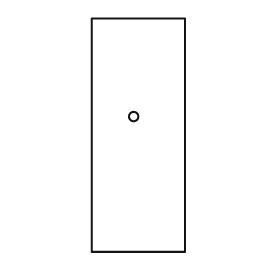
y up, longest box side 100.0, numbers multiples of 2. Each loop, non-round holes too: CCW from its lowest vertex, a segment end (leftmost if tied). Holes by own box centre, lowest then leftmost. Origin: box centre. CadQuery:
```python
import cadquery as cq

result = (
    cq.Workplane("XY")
    .moveTo(-20.0, -50.0)
    .lineTo(20.0, -50.0)
    .lineTo(20.0, 50.0)
    .lineTo(-20.0, 50.0)
    .close()
    .moveTo(-2.0, 8.0)
    .circle(2.0)
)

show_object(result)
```